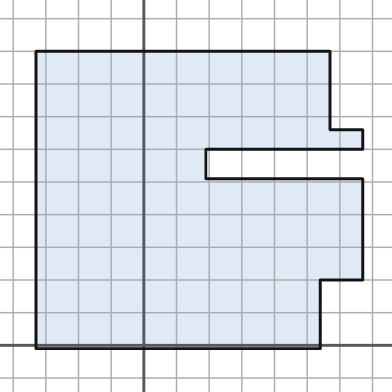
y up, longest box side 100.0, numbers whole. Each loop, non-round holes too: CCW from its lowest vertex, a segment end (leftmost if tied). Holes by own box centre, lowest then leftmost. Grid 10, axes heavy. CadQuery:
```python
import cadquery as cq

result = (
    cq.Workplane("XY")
    .moveTo(-33.0, -1.0)
    .lineTo(54.0, -1.0)
    .lineTo(54.0, 20.0)
    .lineTo(67.0, 20.0)
    .lineTo(67.0, 51.0)
    .lineTo(19.0, 51.0)
    .lineTo(19.0, 60.0)
    .lineTo(67.0, 60.0)
    .lineTo(67.0, 66.0)
    .lineTo(57.0, 66.0)
    .lineTo(57.0, 90.0)
    .lineTo(-33.0, 90.0)
    .close()
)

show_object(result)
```